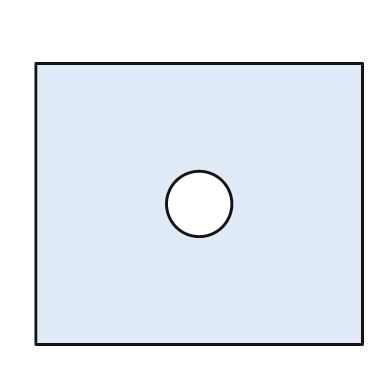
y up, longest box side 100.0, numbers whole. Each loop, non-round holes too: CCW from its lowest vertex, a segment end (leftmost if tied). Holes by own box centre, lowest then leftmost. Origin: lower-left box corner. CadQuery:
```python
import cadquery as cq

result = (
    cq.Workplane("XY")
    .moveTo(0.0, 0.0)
    .lineTo(100.0, 0.0)
    .lineTo(100.0, 86.0)
    .lineTo(0.0, 86.0)
    .close()
    .moveTo(50.0, 43.0)
    .circle(10.0)
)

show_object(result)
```